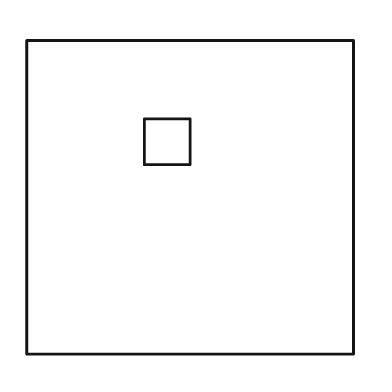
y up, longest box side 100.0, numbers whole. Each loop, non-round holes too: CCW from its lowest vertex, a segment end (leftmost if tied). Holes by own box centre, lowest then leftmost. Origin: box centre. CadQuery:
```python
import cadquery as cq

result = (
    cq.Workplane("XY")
    .moveTo(-50.0, -48.0)
    .lineTo(50.0, -48.0)
    .lineTo(50.0, 48.0)
    .lineTo(-50.0, 48.0)
    .close()
    .moveTo(-14.0, 10.0)
    .lineTo(0.0, 10.0)
    .lineTo(0.0, 24.0)
    .lineTo(-14.0, 24.0)
    .close()
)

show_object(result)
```